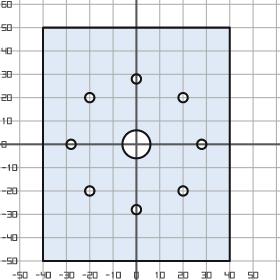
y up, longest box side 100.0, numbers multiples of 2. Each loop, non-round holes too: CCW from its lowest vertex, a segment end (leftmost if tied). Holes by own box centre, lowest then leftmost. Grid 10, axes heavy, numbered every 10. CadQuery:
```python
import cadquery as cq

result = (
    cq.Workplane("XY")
    .moveTo(-40.0, -50.0)
    .lineTo(40.0, -50.0)
    .lineTo(40.0, 50.0)
    .lineTo(-40.0, 50.0)
    .close()
    .moveTo(0.0, -28.0)
    .circle(2.0)
    .moveTo(-20.0, -20.0)
    .circle(2.0)
    .moveTo(20.0, -20.0)
    .circle(2.0)
    .moveTo(-28.0, 0.0)
    .circle(2.0)
    .moveTo(0.0, 0.0)
    .circle(6.0)
    .moveTo(28.0, 0.0)
    .circle(2.0)
    .moveTo(-20.0, 20.0)
    .circle(2.0)
    .moveTo(20.0, 20.0)
    .circle(2.0)
    .moveTo(0.0, 28.0)
    .circle(2.0)
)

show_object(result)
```